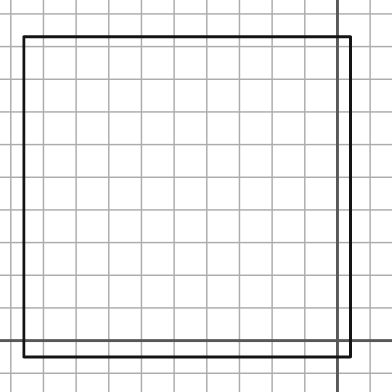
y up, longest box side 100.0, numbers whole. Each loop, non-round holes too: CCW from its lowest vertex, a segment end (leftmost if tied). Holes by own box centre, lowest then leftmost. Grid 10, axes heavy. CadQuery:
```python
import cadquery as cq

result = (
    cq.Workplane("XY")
    .moveTo(-96.0, -5.0)
    .lineTo(4.0, -5.0)
    .lineTo(4.0, 93.0)
    .lineTo(-96.0, 93.0)
    .close()
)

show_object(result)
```